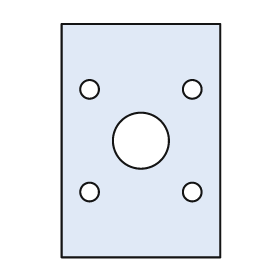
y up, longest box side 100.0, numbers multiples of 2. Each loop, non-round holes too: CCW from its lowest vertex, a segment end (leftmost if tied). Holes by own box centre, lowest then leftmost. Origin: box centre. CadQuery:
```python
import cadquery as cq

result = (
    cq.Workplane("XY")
    .moveTo(-34.0, -50.0)
    .lineTo(34.0, -50.0)
    .lineTo(34.0, 50.0)
    .lineTo(-34.0, 50.0)
    .close()
    .moveTo(-22.0, -22.0)
    .circle(4.0)
    .moveTo(22.0, -22.0)
    .circle(4.0)
    .moveTo(0.0, 0.0)
    .circle(12.0)
    .moveTo(-22.0, 22.0)
    .circle(4.0)
    .moveTo(22.0, 22.0)
    .circle(4.0)
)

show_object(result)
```